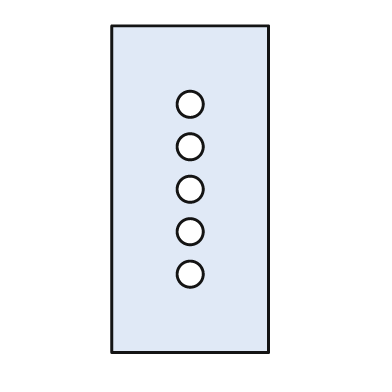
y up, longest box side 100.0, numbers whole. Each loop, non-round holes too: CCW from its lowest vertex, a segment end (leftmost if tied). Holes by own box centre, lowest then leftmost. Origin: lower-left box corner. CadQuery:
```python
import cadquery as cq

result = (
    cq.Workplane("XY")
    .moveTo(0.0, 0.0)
    .lineTo(48.0, 0.0)
    .lineTo(48.0, 100.0)
    .lineTo(0.0, 100.0)
    .close()
    .moveTo(24.0, 24.0)
    .circle(4.0)
    .moveTo(24.0, 37.0)
    .circle(4.0)
    .moveTo(24.0, 50.0)
    .circle(4.0)
    .moveTo(24.0, 63.0)
    .circle(4.0)
    .moveTo(24.0, 76.0)
    .circle(4.0)
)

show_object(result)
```